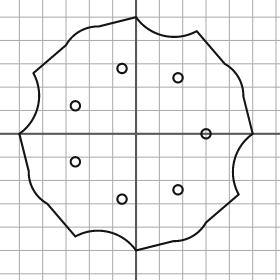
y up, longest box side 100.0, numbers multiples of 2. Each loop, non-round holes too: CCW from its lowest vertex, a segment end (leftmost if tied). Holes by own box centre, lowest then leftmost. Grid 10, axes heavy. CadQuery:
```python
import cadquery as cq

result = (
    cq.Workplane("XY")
    .moveTo(0.0, -50.0)
    .lineTo(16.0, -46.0)
    .threePointArc((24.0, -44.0), (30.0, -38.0))
    .lineTo(44.0, -26.0)
    .threePointArc((42.0, -12.0), (50.0, 0.0))
    .lineTo(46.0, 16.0)
    .threePointArc((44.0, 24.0), (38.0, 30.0))
    .lineTo(26.0, 44.0)
    .threePointArc((12.0, 42.0), (0.0, 50.0))
    .lineTo(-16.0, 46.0)
    .threePointArc((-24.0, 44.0), (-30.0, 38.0))
    .lineTo(-44.0, 26.0)
    .threePointArc((-42.0, 12.0), (-50.0, 0.0))
    .lineTo(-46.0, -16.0)
    .threePointArc((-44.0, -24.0), (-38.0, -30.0))
    .lineTo(-26.0, -44.0)
    .threePointArc((-12.0, -42.0), (0.0, -50.0))
    .close()
    .moveTo(-6.0, -28.0)
    .circle(2.0)
    .moveTo(18.0, -24.0)
    .circle(2.0)
    .moveTo(-26.0, -12.0)
    .circle(2.0)
    .moveTo(30.0, 0.0)
    .circle(2.0)
    .moveTo(-26.0, 12.0)
    .circle(2.0)
    .moveTo(18.0, 24.0)
    .circle(2.0)
    .moveTo(-6.0, 28.0)
    .circle(2.0)
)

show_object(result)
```